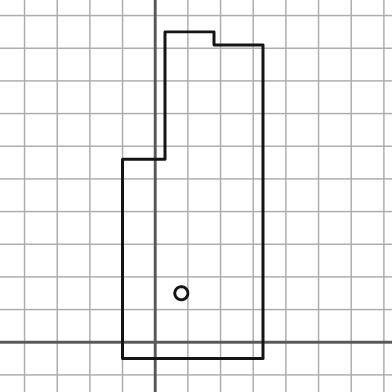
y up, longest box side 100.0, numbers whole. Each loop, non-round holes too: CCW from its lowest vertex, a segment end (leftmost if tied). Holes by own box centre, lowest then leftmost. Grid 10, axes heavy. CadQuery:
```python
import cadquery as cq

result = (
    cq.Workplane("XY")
    .moveTo(-10.0, -5.0)
    .lineTo(33.0, -5.0)
    .lineTo(33.0, 91.0)
    .lineTo(18.0, 91.0)
    .lineTo(18.0, 95.0)
    .lineTo(3.0, 95.0)
    .lineTo(3.0, 56.0)
    .lineTo(-10.0, 56.0)
    .close()
    .moveTo(8.0, 15.0)
    .circle(2.0)
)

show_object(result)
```